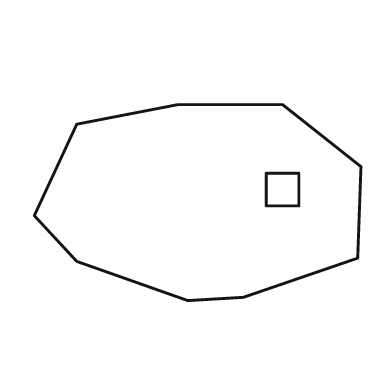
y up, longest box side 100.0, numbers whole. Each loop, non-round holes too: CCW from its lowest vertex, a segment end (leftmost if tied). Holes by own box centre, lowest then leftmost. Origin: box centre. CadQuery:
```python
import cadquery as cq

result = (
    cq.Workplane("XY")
    .moveTo(-3.0, -30.0)
    .lineTo(14.0, -29.0)
    .lineTo(49.0, -17.0)
    .lineTo(50.0, 11.0)
    .lineTo(26.0, 30.0)
    .lineTo(-6.0, 30.0)
    .lineTo(-37.0, 24.0)
    .lineTo(-50.0, -4.0)
    .lineTo(-37.0, -18.0)
    .close()
    .moveTo(21.0, -1.0)
    .lineTo(31.0, -1.0)
    .lineTo(31.0, 9.0)
    .lineTo(21.0, 9.0)
    .close()
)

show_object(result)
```